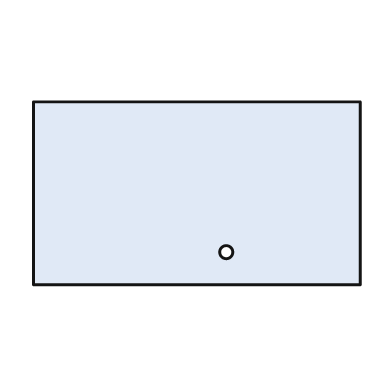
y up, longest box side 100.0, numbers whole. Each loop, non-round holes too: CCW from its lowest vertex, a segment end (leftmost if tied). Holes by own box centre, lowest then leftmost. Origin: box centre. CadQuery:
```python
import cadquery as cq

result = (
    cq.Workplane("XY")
    .moveTo(-50.0, -28.0)
    .lineTo(50.0, -28.0)
    .lineTo(50.0, 28.0)
    .lineTo(-50.0, 28.0)
    .close()
    .moveTo(9.0, -18.0)
    .circle(2.0)
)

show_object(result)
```